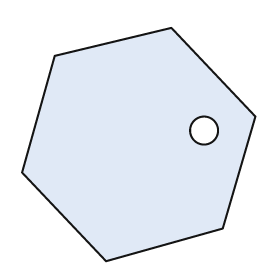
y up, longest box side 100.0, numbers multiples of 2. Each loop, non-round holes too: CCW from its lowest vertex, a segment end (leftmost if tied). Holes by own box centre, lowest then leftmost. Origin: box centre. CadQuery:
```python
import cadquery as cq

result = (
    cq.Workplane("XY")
    .moveTo(-14.0, -50.0)
    .lineTo(36.0, -36.0)
    .lineTo(50.0, 12.0)
    .lineTo(14.0, 50.0)
    .lineTo(-36.0, 38.0)
    .lineTo(-50.0, -12.0)
    .close()
    .moveTo(28.0, 6.0)
    .circle(6.0)
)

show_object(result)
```